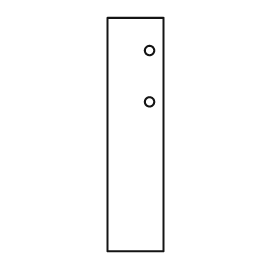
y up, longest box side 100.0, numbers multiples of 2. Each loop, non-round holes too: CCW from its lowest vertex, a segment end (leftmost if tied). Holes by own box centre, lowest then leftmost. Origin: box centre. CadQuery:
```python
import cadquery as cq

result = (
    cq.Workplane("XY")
    .moveTo(-12.0, -50.0)
    .lineTo(12.0, -50.0)
    .lineTo(12.0, 50.0)
    .lineTo(-12.0, 50.0)
    .close()
    .moveTo(6.0, 14.0)
    .circle(2.0)
    .moveTo(6.0, 36.0)
    .circle(2.0)
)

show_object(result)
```